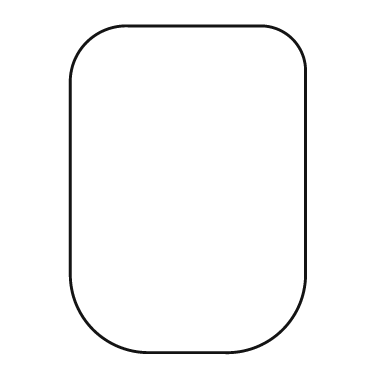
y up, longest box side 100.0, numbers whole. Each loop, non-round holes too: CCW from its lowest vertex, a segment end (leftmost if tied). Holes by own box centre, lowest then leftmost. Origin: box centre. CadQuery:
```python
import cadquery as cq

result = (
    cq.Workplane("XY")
    .moveTo(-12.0, -50.0)
    .lineTo(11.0, -50.0)
    .threePointArc((29.0, -43.0), (36.0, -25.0))
    .lineTo(36.0, 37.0)
    .threePointArc((32.0, 46.0), (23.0, 50.0))
    .lineTo(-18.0, 50.0)
    .threePointArc((-31.0, 45.0), (-36.0, 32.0))
    .lineTo(-36.0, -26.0)
    .threePointArc((-29.0, -43.0), (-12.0, -50.0))
    .close()
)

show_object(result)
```